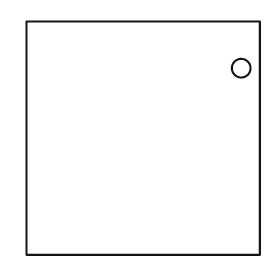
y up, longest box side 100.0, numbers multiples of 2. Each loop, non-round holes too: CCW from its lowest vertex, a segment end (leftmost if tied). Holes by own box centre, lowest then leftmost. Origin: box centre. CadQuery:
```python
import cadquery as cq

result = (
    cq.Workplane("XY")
    .moveTo(-50.0, -50.0)
    .lineTo(50.0, -50.0)
    .lineTo(50.0, 50.0)
    .lineTo(-50.0, 50.0)
    .close()
    .moveTo(42.0, 30.0)
    .circle(4.0)
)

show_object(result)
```